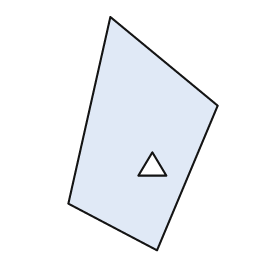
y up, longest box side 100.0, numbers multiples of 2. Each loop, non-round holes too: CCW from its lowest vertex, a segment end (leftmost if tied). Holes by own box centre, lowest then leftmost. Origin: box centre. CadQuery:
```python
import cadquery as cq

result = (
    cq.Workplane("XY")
    .moveTo(6.0, -50.0)
    .lineTo(32.0, 12.0)
    .lineTo(-14.0, 50.0)
    .lineTo(-32.0, -30.0)
    .close()
    .moveTo(-2.0, -18.0)
    .lineTo(10.0, -18.0)
    .lineTo(4.0, -8.0)
    .close()
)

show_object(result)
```